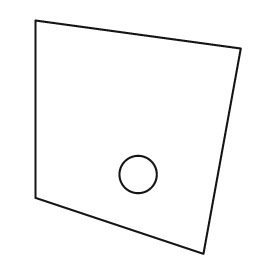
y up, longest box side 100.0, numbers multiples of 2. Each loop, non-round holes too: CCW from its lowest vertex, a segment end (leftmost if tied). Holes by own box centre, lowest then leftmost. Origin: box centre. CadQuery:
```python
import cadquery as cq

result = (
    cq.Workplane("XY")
    .moveTo(28.0, -50.0)
    .lineTo(44.0, 38.0)
    .lineTo(-44.0, 50.0)
    .lineTo(-44.0, -26.0)
    .close()
    .moveTo(0.0, -16.0)
    .circle(8.0)
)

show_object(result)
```